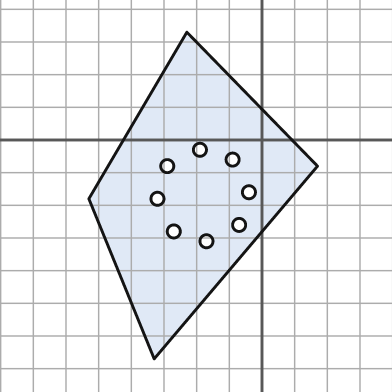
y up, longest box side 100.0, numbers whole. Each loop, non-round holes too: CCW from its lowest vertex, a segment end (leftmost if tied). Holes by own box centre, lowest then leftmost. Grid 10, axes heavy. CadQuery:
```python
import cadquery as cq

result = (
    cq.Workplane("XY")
    .moveTo(-33.0, -67.0)
    .lineTo(17.0, -8.0)
    .lineTo(-23.0, 33.0)
    .lineTo(-53.0, -18.0)
    .close()
    .moveTo(-17.0, -31.0)
    .circle(2.0)
    .moveTo(-27.0, -28.0)
    .circle(2.0)
    .moveTo(-7.0, -26.0)
    .circle(2.0)
    .moveTo(-32.0, -18.0)
    .circle(2.0)
    .moveTo(-4.0, -16.0)
    .circle(2.0)
    .moveTo(-29.0, -8.0)
    .circle(2.0)
    .moveTo(-9.0, -6.0)
    .circle(2.0)
    .moveTo(-19.0, -3.0)
    .circle(2.0)
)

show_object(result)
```